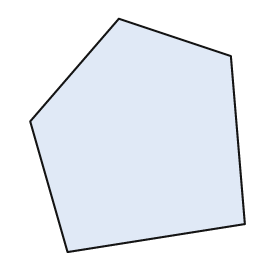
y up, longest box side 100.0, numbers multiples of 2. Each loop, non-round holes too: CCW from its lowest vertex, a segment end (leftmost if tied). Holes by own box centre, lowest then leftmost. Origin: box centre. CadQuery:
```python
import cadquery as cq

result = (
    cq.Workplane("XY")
    .moveTo(-30.0, -50.0)
    .lineTo(46.0, -38.0)
    .lineTo(40.0, 34.0)
    .lineTo(-8.0, 50.0)
    .lineTo(-46.0, 6.0)
    .close()
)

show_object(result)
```